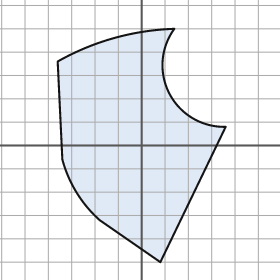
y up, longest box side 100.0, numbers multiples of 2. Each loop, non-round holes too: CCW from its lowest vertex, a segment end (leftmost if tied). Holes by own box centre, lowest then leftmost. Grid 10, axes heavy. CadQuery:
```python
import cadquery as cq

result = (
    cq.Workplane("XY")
    .moveTo(8.0, -50.0)
    .lineTo(36.0, 8.0)
    .threePointArc((12.0, 22.0), (14.0, 50.0))
    .threePointArc((-12.0, 46.0), (-36.0, 36.0))
    .lineTo(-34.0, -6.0)
    .threePointArc((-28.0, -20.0), (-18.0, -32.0))
    .close()
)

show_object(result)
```